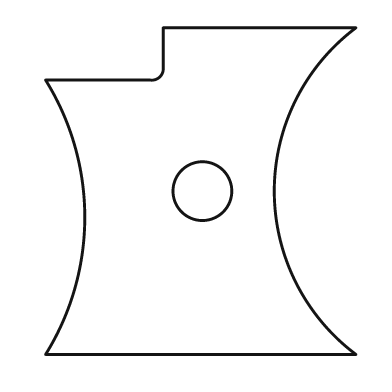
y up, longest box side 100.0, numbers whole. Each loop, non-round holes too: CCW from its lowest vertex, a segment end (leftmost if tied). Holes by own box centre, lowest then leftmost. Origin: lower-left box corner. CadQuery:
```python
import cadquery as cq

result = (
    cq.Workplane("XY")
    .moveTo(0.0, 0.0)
    .lineTo(95.0, 0.0)
    .threePointArc((70.0, 50.0), (95.0, 100.0))
    .lineTo(36.0, 100.0)
    .lineTo(36.0, 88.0)
    .threePointArc((35.0, 85.0), (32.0, 84.0))
    .lineTo(0.0, 84.0)
    .threePointArc((12.0, 42.0), (0.0, 0.0))
    .close()
    .moveTo(48.0, 50.0)
    .circle(9.0)
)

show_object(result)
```